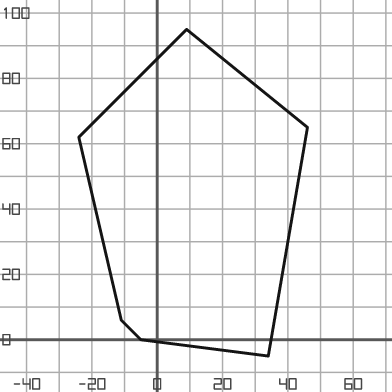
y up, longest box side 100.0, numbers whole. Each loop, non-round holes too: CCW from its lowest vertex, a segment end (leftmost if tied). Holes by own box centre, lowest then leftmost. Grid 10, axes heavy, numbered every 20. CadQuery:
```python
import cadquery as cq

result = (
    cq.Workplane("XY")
    .moveTo(34.0, -5.0)
    .lineTo(46.0, 65.0)
    .lineTo(9.0, 95.0)
    .lineTo(-24.0, 62.0)
    .lineTo(-11.0, 6.0)
    .lineTo(-5.0, 0.0)
    .close()
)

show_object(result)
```